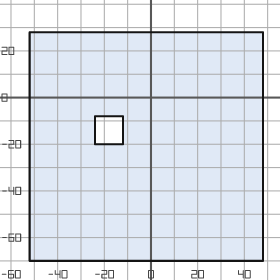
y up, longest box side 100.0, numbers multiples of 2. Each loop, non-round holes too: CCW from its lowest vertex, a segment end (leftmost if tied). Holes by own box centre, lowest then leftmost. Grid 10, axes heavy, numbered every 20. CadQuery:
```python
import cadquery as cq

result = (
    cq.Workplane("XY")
    .moveTo(-52.0, -70.0)
    .lineTo(48.0, -70.0)
    .lineTo(48.0, 28.0)
    .lineTo(-52.0, 28.0)
    .close()
    .moveTo(-24.0, -20.0)
    .lineTo(-12.0, -20.0)
    .lineTo(-12.0, -8.0)
    .lineTo(-24.0, -8.0)
    .close()
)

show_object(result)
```